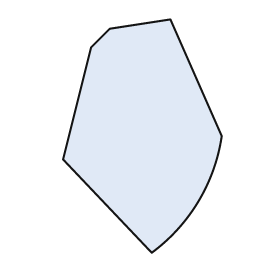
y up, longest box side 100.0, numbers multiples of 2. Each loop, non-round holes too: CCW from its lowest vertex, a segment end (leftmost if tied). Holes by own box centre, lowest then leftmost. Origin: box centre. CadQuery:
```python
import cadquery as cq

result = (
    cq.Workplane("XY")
    .moveTo(4.0, -50.0)
    .threePointArc((24.0, -28.0), (34.0, 0.0))
    .lineTo(12.0, 50.0)
    .lineTo(-14.0, 46.0)
    .lineTo(-22.0, 38.0)
    .lineTo(-34.0, -10.0)
    .close()
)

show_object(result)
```